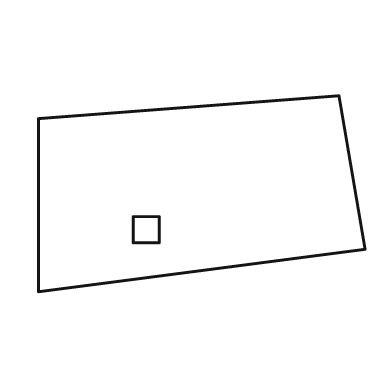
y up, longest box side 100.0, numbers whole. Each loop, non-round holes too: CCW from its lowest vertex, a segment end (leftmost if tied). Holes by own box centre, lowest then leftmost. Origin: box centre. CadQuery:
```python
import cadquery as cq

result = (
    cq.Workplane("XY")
    .moveTo(-50.0, -30.0)
    .lineTo(50.0, -17.0)
    .lineTo(42.0, 30.0)
    .lineTo(-50.0, 23.0)
    .close()
    .moveTo(-21.0, -15.0)
    .lineTo(-13.0, -15.0)
    .lineTo(-13.0, -7.0)
    .lineTo(-21.0, -7.0)
    .close()
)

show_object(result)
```